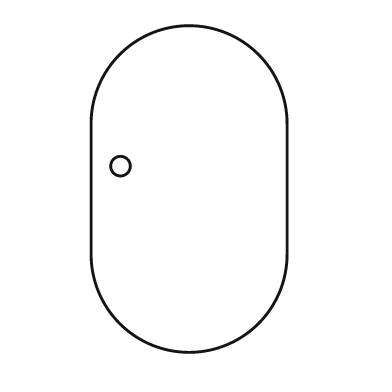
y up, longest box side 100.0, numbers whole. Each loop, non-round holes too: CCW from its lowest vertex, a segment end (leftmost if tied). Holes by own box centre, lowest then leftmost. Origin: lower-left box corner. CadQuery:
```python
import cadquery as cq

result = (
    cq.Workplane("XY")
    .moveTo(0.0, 30.0)
    .threePointArc((30.0, 0.0), (60.0, 30.0))
    .lineTo(60.0, 70.0)
    .threePointArc((30.0, 100.0), (0.0, 70.0))
    .close()
    .moveTo(9.0, 57.0)
    .circle(3.0)
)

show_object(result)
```